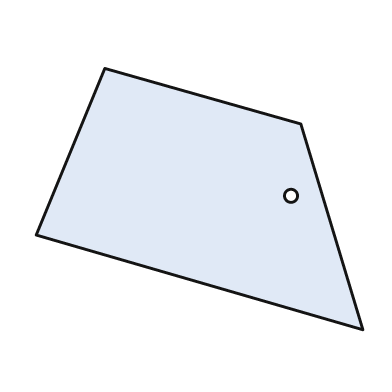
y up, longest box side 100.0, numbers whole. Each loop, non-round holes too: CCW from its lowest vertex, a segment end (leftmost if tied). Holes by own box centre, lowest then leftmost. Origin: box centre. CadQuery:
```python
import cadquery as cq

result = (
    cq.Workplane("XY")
    .moveTo(50.0, -40.0)
    .lineTo(31.0, 23.0)
    .lineTo(-29.0, 40.0)
    .lineTo(-50.0, -11.0)
    .close()
    .moveTo(28.0, 1.0)
    .circle(2.0)
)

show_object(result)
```